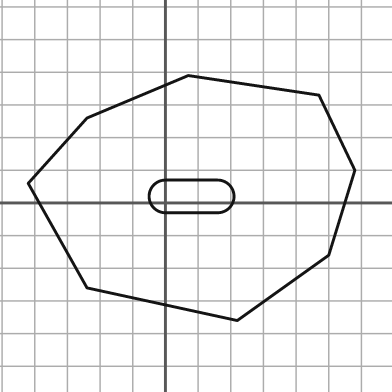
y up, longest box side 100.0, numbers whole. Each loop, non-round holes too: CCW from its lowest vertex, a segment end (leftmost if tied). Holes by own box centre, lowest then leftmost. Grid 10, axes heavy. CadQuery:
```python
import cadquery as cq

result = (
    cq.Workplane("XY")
    .moveTo(22.0, -36.0)
    .lineTo(50.0, -16.0)
    .lineTo(58.0, 10.0)
    .lineTo(47.0, 33.0)
    .lineTo(7.0, 39.0)
    .lineTo(-24.0, 26.0)
    .lineTo(-42.0, 6.0)
    .lineTo(-24.0, -26.0)
    .close()
    .moveTo(0.0, -3.0)
    .lineTo(16.0, -3.0)
    .threePointArc((21.0, 2.0), (16.0, 7.0))
    .lineTo(0.0, 7.0)
    .threePointArc((-5.0, 2.0), (0.0, -3.0))
    .close()
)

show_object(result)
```